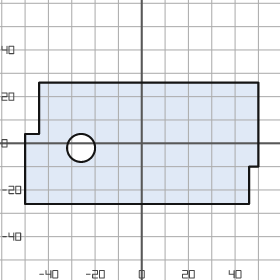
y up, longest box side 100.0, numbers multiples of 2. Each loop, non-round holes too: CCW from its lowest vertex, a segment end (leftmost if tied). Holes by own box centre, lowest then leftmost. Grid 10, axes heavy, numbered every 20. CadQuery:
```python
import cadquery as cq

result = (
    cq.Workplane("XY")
    .moveTo(-50.0, -26.0)
    .lineTo(46.0, -26.0)
    .lineTo(46.0, -10.0)
    .lineTo(50.0, -10.0)
    .lineTo(50.0, 26.0)
    .lineTo(-44.0, 26.0)
    .lineTo(-44.0, 4.0)
    .lineTo(-50.0, 4.0)
    .close()
    .moveTo(-26.0, -2.0)
    .circle(6.0)
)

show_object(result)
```